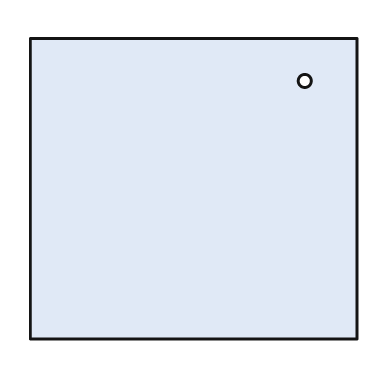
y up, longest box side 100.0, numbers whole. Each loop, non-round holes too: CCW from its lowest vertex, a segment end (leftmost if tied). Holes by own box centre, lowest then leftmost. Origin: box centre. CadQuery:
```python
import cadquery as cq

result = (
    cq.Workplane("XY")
    .moveTo(-50.0, -46.0)
    .lineTo(50.0, -46.0)
    .lineTo(50.0, 46.0)
    .lineTo(-50.0, 46.0)
    .close()
    .moveTo(34.0, 33.0)
    .circle(2.0)
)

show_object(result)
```